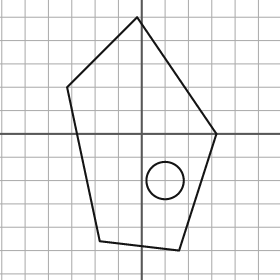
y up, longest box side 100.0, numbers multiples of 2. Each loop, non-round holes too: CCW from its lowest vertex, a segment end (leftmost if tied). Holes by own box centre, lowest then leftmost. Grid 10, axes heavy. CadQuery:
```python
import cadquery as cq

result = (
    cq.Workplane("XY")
    .moveTo(16.0, -50.0)
    .lineTo(32.0, 0.0)
    .lineTo(-2.0, 50.0)
    .lineTo(-32.0, 20.0)
    .lineTo(-18.0, -46.0)
    .close()
    .moveTo(10.0, -20.0)
    .circle(8.0)
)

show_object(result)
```